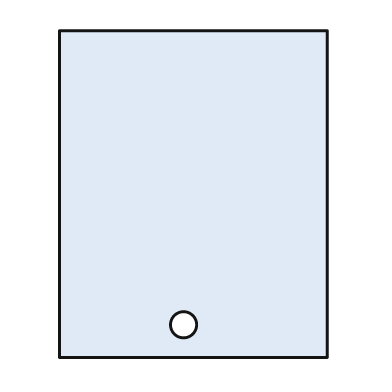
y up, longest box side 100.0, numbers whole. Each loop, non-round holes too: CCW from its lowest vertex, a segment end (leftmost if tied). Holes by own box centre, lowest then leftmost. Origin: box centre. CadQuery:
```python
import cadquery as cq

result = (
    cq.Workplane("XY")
    .moveTo(-41.0, -50.0)
    .lineTo(41.0, -50.0)
    .lineTo(41.0, 50.0)
    .lineTo(-41.0, 50.0)
    .close()
    .moveTo(-3.0, -40.0)
    .circle(4.0)
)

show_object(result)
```